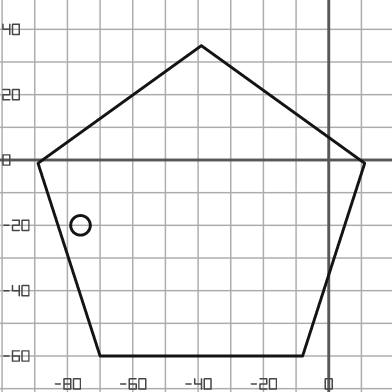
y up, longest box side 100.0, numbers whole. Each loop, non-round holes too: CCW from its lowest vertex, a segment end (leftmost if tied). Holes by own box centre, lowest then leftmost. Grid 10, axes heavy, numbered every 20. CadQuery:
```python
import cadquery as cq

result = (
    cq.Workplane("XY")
    .moveTo(-70.0, -60.0)
    .lineTo(-8.0, -60.0)
    .lineTo(11.0, -1.0)
    .lineTo(-39.0, 35.0)
    .lineTo(-89.0, -1.0)
    .close()
    .moveTo(-76.0, -20.0)
    .circle(3.0)
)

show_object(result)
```